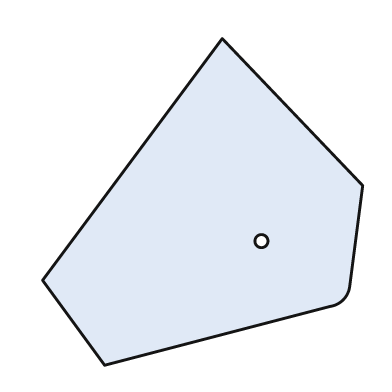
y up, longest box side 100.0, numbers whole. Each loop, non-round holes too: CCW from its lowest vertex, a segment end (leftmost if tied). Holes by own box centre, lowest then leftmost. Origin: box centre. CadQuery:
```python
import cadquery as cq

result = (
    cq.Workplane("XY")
    .moveTo(-30.0, -50.0)
    .lineTo(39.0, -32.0)
    .threePointArc((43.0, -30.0), (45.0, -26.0))
    .lineTo(49.0, 5.0)
    .lineTo(6.0, 50.0)
    .lineTo(-49.0, -24.0)
    .close()
    .moveTo(18.0, -12.0)
    .circle(2.0)
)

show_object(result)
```